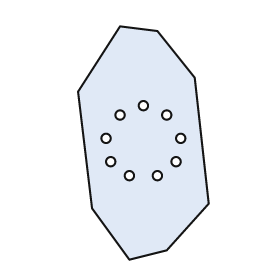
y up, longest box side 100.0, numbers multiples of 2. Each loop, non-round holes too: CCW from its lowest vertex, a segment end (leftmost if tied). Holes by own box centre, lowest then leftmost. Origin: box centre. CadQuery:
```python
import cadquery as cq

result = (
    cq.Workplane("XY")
    .moveTo(-6.0, -50.0)
    .lineTo(10.0, -46.0)
    .lineTo(28.0, -26.0)
    .lineTo(22.0, 28.0)
    .lineTo(6.0, 48.0)
    .lineTo(-10.0, 50.0)
    .lineTo(-28.0, 22.0)
    .lineTo(-22.0, -28.0)
    .close()
    .moveTo(-6.0, -14.0)
    .circle(2.0)
    .moveTo(6.0, -14.0)
    .circle(2.0)
    .moveTo(-14.0, -8.0)
    .circle(2.0)
    .moveTo(14.0, -8.0)
    .circle(2.0)
    .moveTo(-16.0, 2.0)
    .circle(2.0)
    .moveTo(16.0, 2.0)
    .circle(2.0)
    .moveTo(-10.0, 12.0)
    .circle(2.0)
    .moveTo(10.0, 12.0)
    .circle(2.0)
    .moveTo(0.0, 16.0)
    .circle(2.0)
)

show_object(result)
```